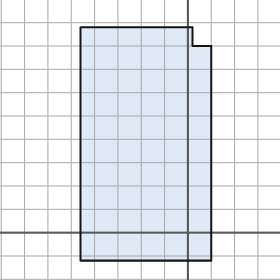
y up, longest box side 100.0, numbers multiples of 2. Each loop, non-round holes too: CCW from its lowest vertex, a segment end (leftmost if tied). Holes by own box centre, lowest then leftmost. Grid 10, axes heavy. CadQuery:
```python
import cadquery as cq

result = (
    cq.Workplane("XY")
    .moveTo(-46.0, -12.0)
    .lineTo(10.0, -12.0)
    .lineTo(10.0, 80.0)
    .lineTo(2.0, 80.0)
    .lineTo(2.0, 88.0)
    .lineTo(-46.0, 88.0)
    .close()
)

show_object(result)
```